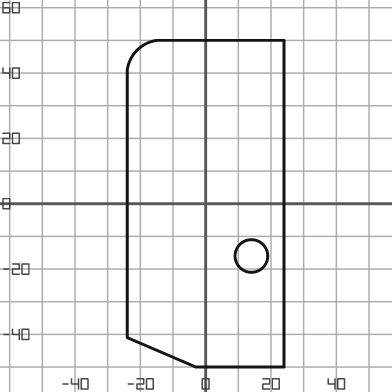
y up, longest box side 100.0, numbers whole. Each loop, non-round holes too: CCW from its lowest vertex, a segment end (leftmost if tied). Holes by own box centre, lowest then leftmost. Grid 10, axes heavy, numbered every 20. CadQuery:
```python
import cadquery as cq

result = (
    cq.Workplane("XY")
    .moveTo(-3.0, -50.0)
    .lineTo(24.0, -50.0)
    .lineTo(24.0, 50.0)
    .lineTo(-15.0, 50.0)
    .threePointArc((-21.0, 47.0), (-24.0, 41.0))
    .lineTo(-24.0, -41.0)
    .close()
    .moveTo(14.0, -16.0)
    .circle(5.0)
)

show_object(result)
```